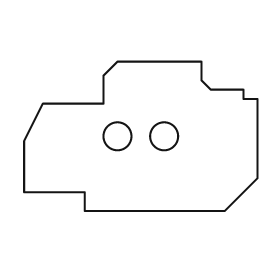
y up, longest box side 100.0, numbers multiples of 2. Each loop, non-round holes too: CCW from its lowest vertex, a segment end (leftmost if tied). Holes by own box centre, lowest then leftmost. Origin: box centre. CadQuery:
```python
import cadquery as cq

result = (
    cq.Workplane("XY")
    .moveTo(-24.0, -32.0)
    .lineTo(36.0, -32.0)
    .lineTo(50.0, -18.0)
    .lineTo(50.0, 16.0)
    .lineTo(44.0, 16.0)
    .lineTo(44.0, 20.0)
    .lineTo(30.0, 20.0)
    .lineTo(26.0, 24.0)
    .lineTo(26.0, 32.0)
    .lineTo(-10.0, 32.0)
    .lineTo(-16.0, 26.0)
    .lineTo(-16.0, 14.0)
    .lineTo(-42.0, 14.0)
    .lineTo(-50.0, -2.0)
    .lineTo(-50.0, -24.0)
    .lineTo(-24.0, -24.0)
    .close()
    .moveTo(-10.0, 0.0)
    .circle(6.0)
    .moveTo(10.0, 0.0)
    .circle(6.0)
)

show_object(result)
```